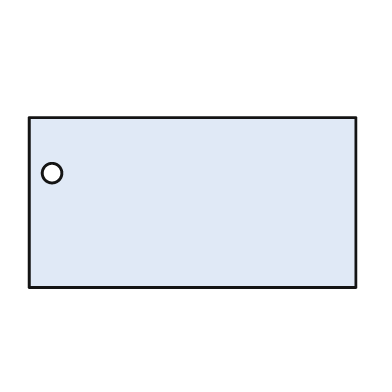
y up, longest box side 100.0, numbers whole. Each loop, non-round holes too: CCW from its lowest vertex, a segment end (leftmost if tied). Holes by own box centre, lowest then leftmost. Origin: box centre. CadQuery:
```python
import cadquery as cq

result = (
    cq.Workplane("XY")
    .moveTo(-50.0, -26.0)
    .lineTo(50.0, -26.0)
    .lineTo(50.0, 26.0)
    .lineTo(-50.0, 26.0)
    .close()
    .moveTo(-43.0, 9.0)
    .circle(3.0)
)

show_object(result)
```